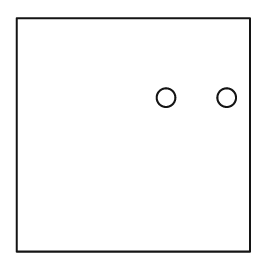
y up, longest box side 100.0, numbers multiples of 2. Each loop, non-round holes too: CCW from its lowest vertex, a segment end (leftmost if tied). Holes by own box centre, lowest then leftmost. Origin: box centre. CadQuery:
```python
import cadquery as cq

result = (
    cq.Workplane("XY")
    .moveTo(-50.0, -50.0)
    .lineTo(50.0, -50.0)
    .lineTo(50.0, 50.0)
    .lineTo(-50.0, 50.0)
    .close()
    .moveTo(14.0, 16.0)
    .circle(4.0)
    .moveTo(40.0, 16.0)
    .circle(4.0)
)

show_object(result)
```